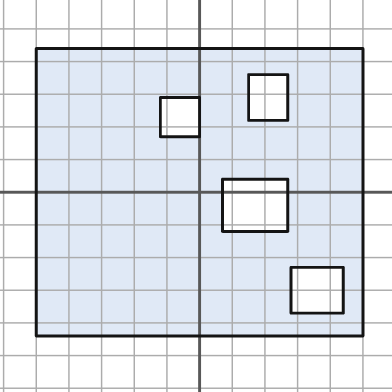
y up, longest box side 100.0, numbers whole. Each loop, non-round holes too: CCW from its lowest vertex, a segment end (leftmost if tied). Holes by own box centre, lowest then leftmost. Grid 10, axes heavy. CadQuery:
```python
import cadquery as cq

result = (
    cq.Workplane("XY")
    .moveTo(-50.0, -44.0)
    .lineTo(50.0, -44.0)
    .lineTo(50.0, 44.0)
    .lineTo(-50.0, 44.0)
    .close()
    .moveTo(28.0, -37.0)
    .lineTo(44.0, -37.0)
    .lineTo(44.0, -23.0)
    .lineTo(28.0, -23.0)
    .close()
    .moveTo(7.0, -12.0)
    .lineTo(27.0, -12.0)
    .lineTo(27.0, 4.0)
    .lineTo(7.0, 4.0)
    .close()
    .moveTo(-12.0, 17.0)
    .lineTo(0.0, 17.0)
    .lineTo(0.0, 29.0)
    .lineTo(-12.0, 29.0)
    .close()
    .moveTo(15.0, 22.0)
    .lineTo(27.0, 22.0)
    .lineTo(27.0, 36.0)
    .lineTo(15.0, 36.0)
    .close()
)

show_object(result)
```